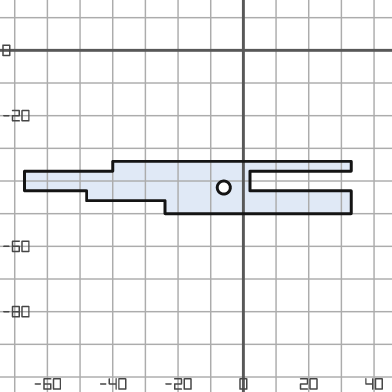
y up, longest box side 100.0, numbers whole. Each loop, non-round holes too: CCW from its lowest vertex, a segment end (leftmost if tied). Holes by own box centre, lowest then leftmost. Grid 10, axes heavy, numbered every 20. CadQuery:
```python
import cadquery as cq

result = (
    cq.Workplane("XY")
    .moveTo(-24.0, -50.0)
    .lineTo(33.0, -50.0)
    .lineTo(33.0, -43.0)
    .lineTo(2.0, -43.0)
    .lineTo(2.0, -37.0)
    .lineTo(33.0, -37.0)
    .lineTo(33.0, -34.0)
    .lineTo(-40.0, -34.0)
    .lineTo(-40.0, -37.0)
    .lineTo(-67.0, -37.0)
    .lineTo(-67.0, -43.0)
    .lineTo(-48.0, -43.0)
    .lineTo(-48.0, -46.0)
    .lineTo(-24.0, -46.0)
    .close()
    .moveTo(-6.0, -42.0)
    .circle(2.0)
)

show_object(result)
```